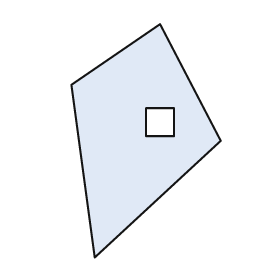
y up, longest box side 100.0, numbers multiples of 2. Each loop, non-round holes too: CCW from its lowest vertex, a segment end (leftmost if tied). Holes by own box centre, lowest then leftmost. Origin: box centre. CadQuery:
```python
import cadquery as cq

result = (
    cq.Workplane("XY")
    .moveTo(-22.0, -50.0)
    .lineTo(32.0, 0.0)
    .lineTo(6.0, 50.0)
    .lineTo(-32.0, 24.0)
    .close()
    .moveTo(0.0, 2.0)
    .lineTo(12.0, 2.0)
    .lineTo(12.0, 14.0)
    .lineTo(0.0, 14.0)
    .close()
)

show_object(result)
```